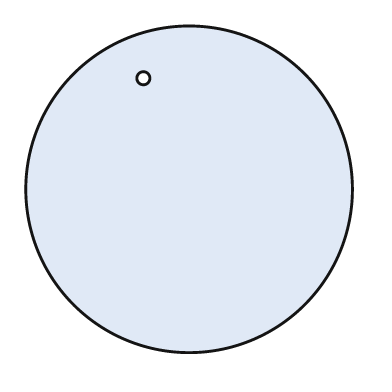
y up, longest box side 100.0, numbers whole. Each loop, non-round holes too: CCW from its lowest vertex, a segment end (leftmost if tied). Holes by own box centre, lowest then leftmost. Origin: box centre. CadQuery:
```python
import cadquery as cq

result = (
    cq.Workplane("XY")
    .moveTo(0.0, 0.0)
    .circle(50.0)
    .moveTo(-14.0, 34.0)
    .circle(2.0)
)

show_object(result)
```